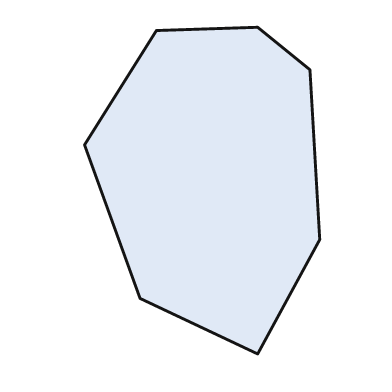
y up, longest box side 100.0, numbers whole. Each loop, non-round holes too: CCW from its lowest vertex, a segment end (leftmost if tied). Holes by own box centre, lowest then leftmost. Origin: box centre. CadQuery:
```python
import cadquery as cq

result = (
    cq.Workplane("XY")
    .moveTo(17.0, -50.0)
    .lineTo(36.0, -15.0)
    .lineTo(33.0, 37.0)
    .lineTo(17.0, 50.0)
    .lineTo(-14.0, 49.0)
    .lineTo(-36.0, 14.0)
    .lineTo(-19.0, -33.0)
    .close()
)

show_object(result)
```